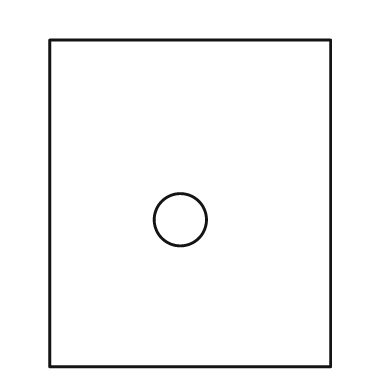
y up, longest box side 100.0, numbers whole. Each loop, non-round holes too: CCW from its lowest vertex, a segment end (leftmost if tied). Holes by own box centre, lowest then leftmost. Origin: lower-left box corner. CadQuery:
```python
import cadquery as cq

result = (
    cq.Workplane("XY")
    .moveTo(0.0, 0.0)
    .lineTo(86.0, 0.0)
    .lineTo(86.0, 100.0)
    .lineTo(0.0, 100.0)
    .close()
    .moveTo(40.0, 45.0)
    .circle(8.0)
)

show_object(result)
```